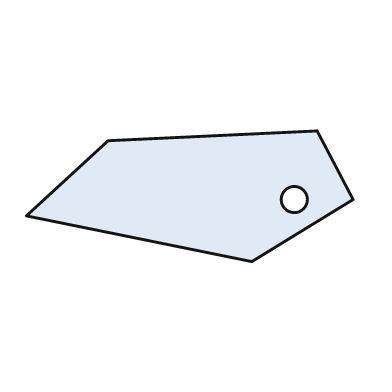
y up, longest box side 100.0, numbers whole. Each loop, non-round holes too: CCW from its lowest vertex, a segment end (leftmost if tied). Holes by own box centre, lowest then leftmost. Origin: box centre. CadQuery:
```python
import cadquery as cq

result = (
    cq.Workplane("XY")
    .moveTo(19.0, -20.0)
    .lineTo(50.0, -1.0)
    .lineTo(39.0, 20.0)
    .lineTo(-25.0, 17.0)
    .lineTo(-50.0, -6.0)
    .close()
    .moveTo(32.0, -1.0)
    .circle(4.0)
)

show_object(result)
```